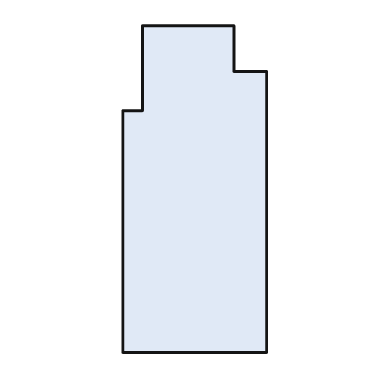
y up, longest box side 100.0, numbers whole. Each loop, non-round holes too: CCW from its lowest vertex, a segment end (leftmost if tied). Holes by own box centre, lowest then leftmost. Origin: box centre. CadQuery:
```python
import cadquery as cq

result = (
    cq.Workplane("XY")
    .moveTo(-22.0, -50.0)
    .lineTo(22.0, -50.0)
    .lineTo(22.0, 36.0)
    .lineTo(12.0, 36.0)
    .lineTo(12.0, 50.0)
    .lineTo(-16.0, 50.0)
    .lineTo(-16.0, 24.0)
    .lineTo(-22.0, 24.0)
    .close()
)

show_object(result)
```